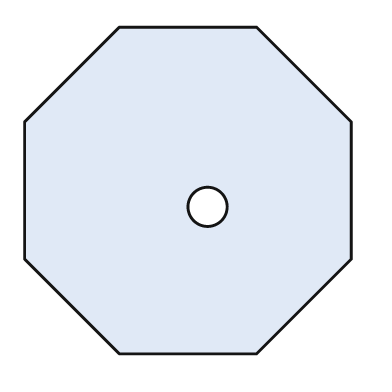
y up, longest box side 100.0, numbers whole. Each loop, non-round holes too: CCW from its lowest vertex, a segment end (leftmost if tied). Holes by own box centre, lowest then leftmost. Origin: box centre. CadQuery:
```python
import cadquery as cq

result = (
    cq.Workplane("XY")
    .moveTo(-21.0, -50.0)
    .lineTo(21.0, -50.0)
    .lineTo(50.0, -21.0)
    .lineTo(50.0, 21.0)
    .lineTo(21.0, 50.0)
    .lineTo(-21.0, 50.0)
    .lineTo(-50.0, 21.0)
    .lineTo(-50.0, -21.0)
    .close()
    .moveTo(6.0, -5.0)
    .circle(6.0)
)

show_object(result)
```